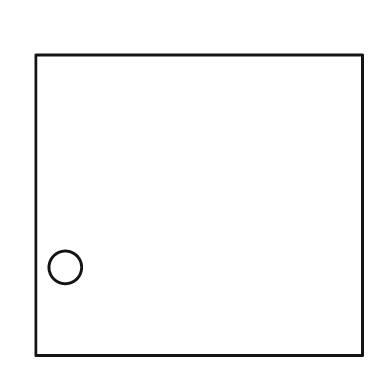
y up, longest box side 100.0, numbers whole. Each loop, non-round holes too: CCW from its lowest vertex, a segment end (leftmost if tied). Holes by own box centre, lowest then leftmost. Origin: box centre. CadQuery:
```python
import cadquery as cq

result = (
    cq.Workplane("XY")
    .moveTo(-50.0, -46.0)
    .lineTo(50.0, -46.0)
    .lineTo(50.0, 46.0)
    .lineTo(-50.0, 46.0)
    .close()
    .moveTo(-41.0, -19.0)
    .circle(5.0)
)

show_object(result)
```